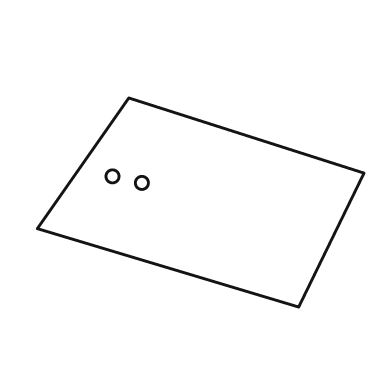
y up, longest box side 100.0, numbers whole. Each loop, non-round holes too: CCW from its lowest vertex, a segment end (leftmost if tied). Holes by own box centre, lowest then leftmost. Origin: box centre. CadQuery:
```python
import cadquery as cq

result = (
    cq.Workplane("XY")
    .moveTo(30.0, -32.0)
    .lineTo(50.0, 9.0)
    .lineTo(-22.0, 32.0)
    .lineTo(-50.0, -8.0)
    .close()
    .moveTo(-18.0, 6.0)
    .circle(2.0)
    .moveTo(-27.0, 8.0)
    .circle(2.0)
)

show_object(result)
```